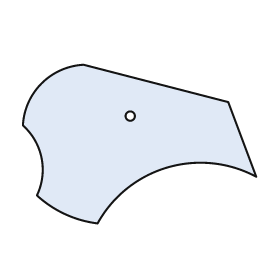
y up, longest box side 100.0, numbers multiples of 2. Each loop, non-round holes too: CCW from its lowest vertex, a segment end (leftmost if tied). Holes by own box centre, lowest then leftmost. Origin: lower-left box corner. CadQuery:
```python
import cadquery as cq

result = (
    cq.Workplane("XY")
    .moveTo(32.0, 0.0)
    .threePointArc((62.0, 24.0), (100.0, 20.0))
    .lineTo(88.0, 52.0)
    .lineTo(26.0, 68.0)
    .threePointArc((8.0, 60.0), (0.0, 42.0))
    .threePointArc((8.0, 28.0), (6.0, 12.0))
    .threePointArc((18.0, 4.0), (32.0, 0.0))
    .close()
    .moveTo(46.0, 46.0)
    .circle(2.0)
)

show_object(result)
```